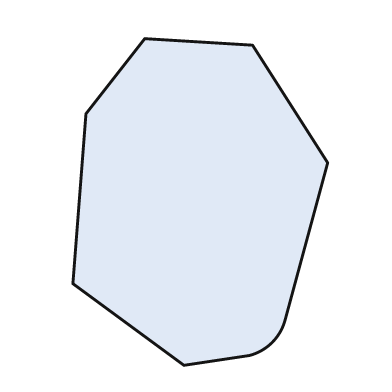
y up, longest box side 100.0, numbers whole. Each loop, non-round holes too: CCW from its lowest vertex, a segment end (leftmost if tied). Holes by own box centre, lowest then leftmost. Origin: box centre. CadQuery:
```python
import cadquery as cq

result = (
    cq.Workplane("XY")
    .moveTo(-5.0, -50.0)
    .lineTo(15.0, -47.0)
    .threePointArc((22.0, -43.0), (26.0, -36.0))
    .lineTo(39.0, 12.0)
    .lineTo(16.0, 48.0)
    .lineTo(-17.0, 50.0)
    .lineTo(-35.0, 27.0)
    .lineTo(-39.0, -25.0)
    .close()
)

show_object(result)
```